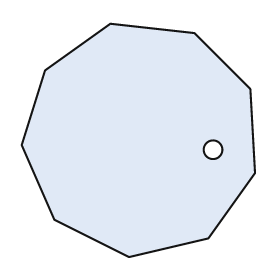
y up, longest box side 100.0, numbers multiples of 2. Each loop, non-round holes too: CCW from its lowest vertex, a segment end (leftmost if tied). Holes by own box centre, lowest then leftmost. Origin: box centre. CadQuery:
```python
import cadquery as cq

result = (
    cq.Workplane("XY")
    .moveTo(-4.0, -50.0)
    .lineTo(30.0, -42.0)
    .lineTo(50.0, -14.0)
    .lineTo(48.0, 22.0)
    .lineTo(24.0, 46.0)
    .lineTo(-12.0, 50.0)
    .lineTo(-40.0, 30.0)
    .lineTo(-50.0, -2.0)
    .lineTo(-36.0, -34.0)
    .close()
    .moveTo(32.0, -4.0)
    .circle(4.0)
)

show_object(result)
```